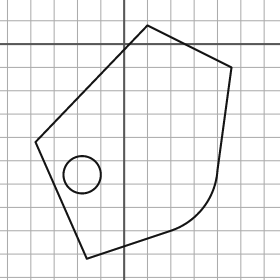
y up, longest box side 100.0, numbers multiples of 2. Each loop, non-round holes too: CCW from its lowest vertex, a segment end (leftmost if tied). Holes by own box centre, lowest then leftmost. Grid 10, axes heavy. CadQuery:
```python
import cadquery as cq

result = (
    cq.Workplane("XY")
    .moveTo(-16.0, -92.0)
    .lineTo(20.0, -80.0)
    .threePointArc((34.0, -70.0), (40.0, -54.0))
    .lineTo(46.0, -10.0)
    .lineTo(10.0, 8.0)
    .lineTo(-38.0, -42.0)
    .close()
    .moveTo(-18.0, -56.0)
    .circle(8.0)
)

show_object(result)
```